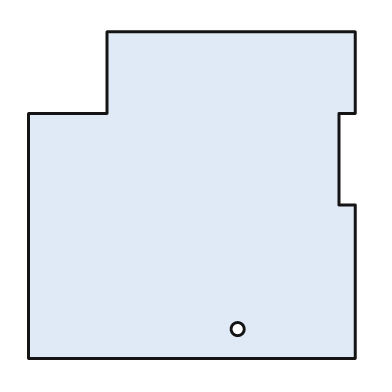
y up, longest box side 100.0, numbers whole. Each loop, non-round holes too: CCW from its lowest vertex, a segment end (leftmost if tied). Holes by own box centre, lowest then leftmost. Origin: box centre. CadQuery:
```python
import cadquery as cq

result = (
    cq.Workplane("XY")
    .moveTo(-50.0, -50.0)
    .lineTo(50.0, -50.0)
    .lineTo(50.0, -3.0)
    .lineTo(45.0, -3.0)
    .lineTo(45.0, 25.0)
    .lineTo(50.0, 25.0)
    .lineTo(50.0, 50.0)
    .lineTo(-26.0, 50.0)
    .lineTo(-26.0, 25.0)
    .lineTo(-50.0, 25.0)
    .close()
    .moveTo(14.0, -41.0)
    .circle(2.0)
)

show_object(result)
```